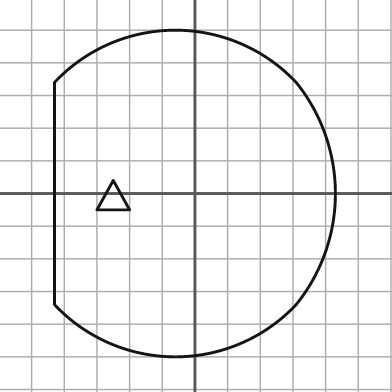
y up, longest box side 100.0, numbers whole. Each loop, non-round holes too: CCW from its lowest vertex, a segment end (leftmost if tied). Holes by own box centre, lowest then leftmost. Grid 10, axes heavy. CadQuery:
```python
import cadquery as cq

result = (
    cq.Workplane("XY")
    .moveTo(-43.0, -34.0)
    .threePointArc((-6.0, -50.0), (31.0, -34.0))
    .threePointArc((43.0, 0.0), (31.0, 34.0))
    .threePointArc((-6.0, 50.0), (-43.0, 34.0))
    .close()
    .moveTo(-30.0, -5.0)
    .lineTo(-20.0, -5.0)
    .lineTo(-25.0, 4.0)
    .close()
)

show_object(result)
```